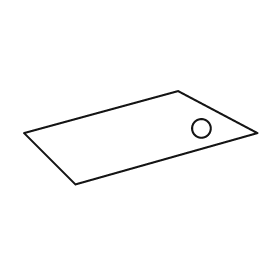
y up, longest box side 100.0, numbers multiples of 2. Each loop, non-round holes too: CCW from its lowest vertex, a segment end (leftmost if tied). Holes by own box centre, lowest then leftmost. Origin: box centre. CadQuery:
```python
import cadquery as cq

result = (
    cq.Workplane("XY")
    .moveTo(-28.0, -20.0)
    .lineTo(50.0, 2.0)
    .lineTo(16.0, 20.0)
    .lineTo(-50.0, 2.0)
    .close()
    .moveTo(26.0, 4.0)
    .circle(4.0)
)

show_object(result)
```